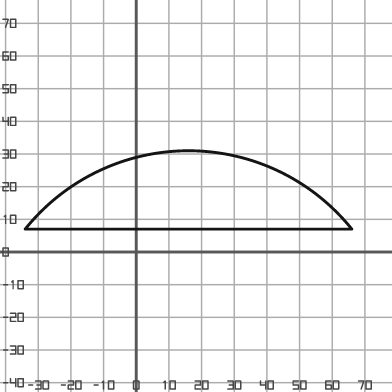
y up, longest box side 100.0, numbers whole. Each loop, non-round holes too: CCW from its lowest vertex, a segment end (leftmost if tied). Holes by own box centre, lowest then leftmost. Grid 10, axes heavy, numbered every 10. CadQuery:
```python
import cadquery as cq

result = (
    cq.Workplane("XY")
    .moveTo(-34.0, 7.0)
    .lineTo(66.0, 7.0)
    .threePointArc((16.0, 31.0), (-34.0, 7.0))
    .close()
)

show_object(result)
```